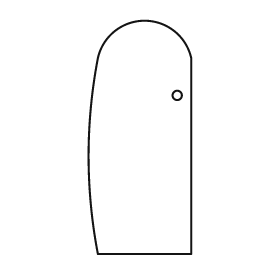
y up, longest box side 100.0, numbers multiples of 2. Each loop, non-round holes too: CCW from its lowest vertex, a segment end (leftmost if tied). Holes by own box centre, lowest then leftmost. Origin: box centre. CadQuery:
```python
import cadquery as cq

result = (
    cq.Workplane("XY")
    .moveTo(-18.0, -50.0)
    .lineTo(22.0, -50.0)
    .lineTo(22.0, 34.0)
    .threePointArc((2.0, 50.0), (-18.0, 34.0))
    .threePointArc((-22.0, -8.0), (-18.0, -50.0))
    .close()
    .moveTo(16.0, 18.0)
    .circle(2.0)
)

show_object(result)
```